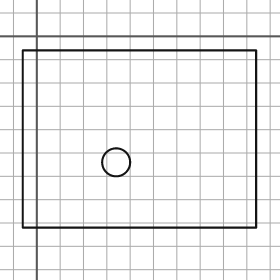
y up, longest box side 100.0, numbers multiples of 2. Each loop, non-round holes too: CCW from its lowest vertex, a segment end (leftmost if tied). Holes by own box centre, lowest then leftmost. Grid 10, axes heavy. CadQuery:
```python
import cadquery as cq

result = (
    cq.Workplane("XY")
    .moveTo(-6.0, -82.0)
    .lineTo(94.0, -82.0)
    .lineTo(94.0, -6.0)
    .lineTo(-6.0, -6.0)
    .close()
    .moveTo(34.0, -54.0)
    .circle(6.0)
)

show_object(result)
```